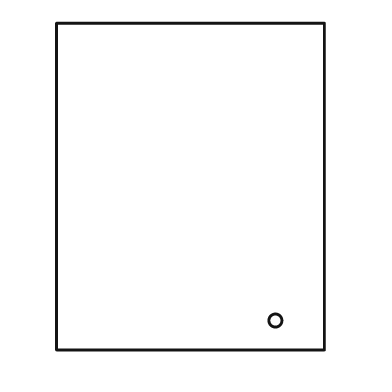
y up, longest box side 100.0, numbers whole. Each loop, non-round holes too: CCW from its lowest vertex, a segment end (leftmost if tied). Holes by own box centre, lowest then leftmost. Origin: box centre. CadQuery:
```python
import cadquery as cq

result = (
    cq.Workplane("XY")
    .moveTo(-41.0, -50.0)
    .lineTo(41.0, -50.0)
    .lineTo(41.0, 50.0)
    .lineTo(-41.0, 50.0)
    .close()
    .moveTo(26.0, -41.0)
    .circle(2.0)
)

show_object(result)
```